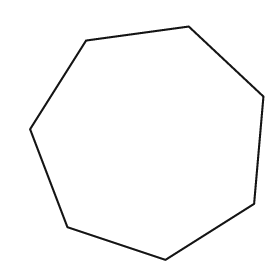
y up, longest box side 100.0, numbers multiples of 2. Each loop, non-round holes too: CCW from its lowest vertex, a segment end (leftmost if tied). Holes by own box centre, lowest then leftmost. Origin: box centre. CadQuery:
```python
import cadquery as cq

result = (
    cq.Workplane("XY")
    .moveTo(8.0, -50.0)
    .lineTo(46.0, -26.0)
    .lineTo(50.0, 20.0)
    .lineTo(18.0, 50.0)
    .lineTo(-26.0, 44.0)
    .lineTo(-50.0, 6.0)
    .lineTo(-34.0, -36.0)
    .close()
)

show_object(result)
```